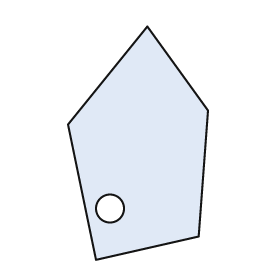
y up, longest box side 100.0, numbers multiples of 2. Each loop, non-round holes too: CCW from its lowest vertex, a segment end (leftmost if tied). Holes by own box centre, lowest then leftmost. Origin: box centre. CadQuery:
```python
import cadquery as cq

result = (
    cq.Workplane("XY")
    .moveTo(-18.0, -50.0)
    .lineTo(26.0, -40.0)
    .lineTo(30.0, 14.0)
    .lineTo(4.0, 50.0)
    .lineTo(-30.0, 8.0)
    .close()
    .moveTo(-12.0, -28.0)
    .circle(6.0)
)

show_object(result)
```